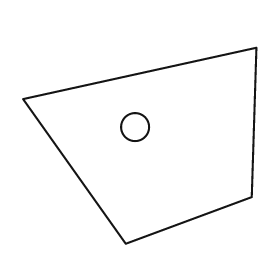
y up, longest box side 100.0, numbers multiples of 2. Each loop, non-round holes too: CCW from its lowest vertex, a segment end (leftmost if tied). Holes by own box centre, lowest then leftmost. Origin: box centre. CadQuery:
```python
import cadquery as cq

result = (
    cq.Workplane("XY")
    .moveTo(-6.0, -42.0)
    .lineTo(48.0, -22.0)
    .lineTo(50.0, 42.0)
    .lineTo(-50.0, 20.0)
    .close()
    .moveTo(-2.0, 8.0)
    .circle(6.0)
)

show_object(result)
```